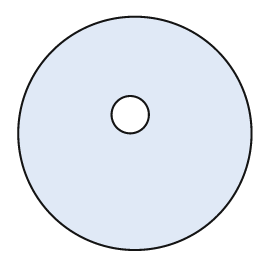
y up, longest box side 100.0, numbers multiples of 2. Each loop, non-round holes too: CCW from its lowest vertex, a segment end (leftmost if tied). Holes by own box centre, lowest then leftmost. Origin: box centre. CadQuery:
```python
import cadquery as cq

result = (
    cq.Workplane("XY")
    .moveTo(0.0, 0.0)
    .circle(50.0)
    .moveTo(-2.0, 8.0)
    .circle(8.0)
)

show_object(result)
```